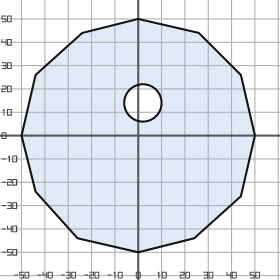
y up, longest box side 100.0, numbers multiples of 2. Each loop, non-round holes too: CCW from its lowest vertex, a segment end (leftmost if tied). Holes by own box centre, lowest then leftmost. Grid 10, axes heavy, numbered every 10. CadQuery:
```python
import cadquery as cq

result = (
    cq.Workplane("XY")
    .moveTo(0.0, -50.0)
    .lineTo(24.0, -44.0)
    .lineTo(44.0, -26.0)
    .lineTo(50.0, 0.0)
    .lineTo(44.0, 26.0)
    .lineTo(26.0, 44.0)
    .lineTo(0.0, 50.0)
    .lineTo(-24.0, 44.0)
    .lineTo(-44.0, 26.0)
    .lineTo(-50.0, 0.0)
    .lineTo(-44.0, -24.0)
    .lineTo(-26.0, -44.0)
    .close()
    .moveTo(2.0, 14.0)
    .circle(8.0)
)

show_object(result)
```